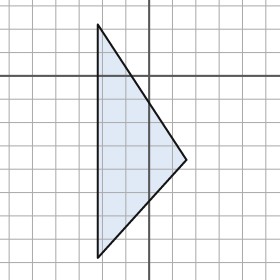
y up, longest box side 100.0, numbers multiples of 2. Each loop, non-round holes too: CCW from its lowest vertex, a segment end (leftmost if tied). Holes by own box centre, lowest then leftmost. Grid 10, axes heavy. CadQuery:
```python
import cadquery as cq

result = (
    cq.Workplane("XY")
    .moveTo(-22.0, -78.0)
    .lineTo(16.0, -36.0)
    .lineTo(-22.0, 22.0)
    .close()
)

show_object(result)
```